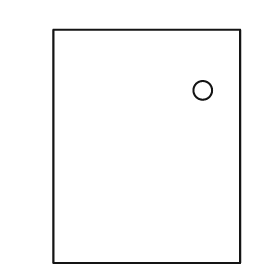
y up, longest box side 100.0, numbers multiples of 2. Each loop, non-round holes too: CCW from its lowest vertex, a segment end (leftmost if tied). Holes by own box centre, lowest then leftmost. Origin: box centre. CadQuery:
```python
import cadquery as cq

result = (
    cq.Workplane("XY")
    .moveTo(-40.0, -50.0)
    .lineTo(40.0, -50.0)
    .lineTo(40.0, 50.0)
    .lineTo(-40.0, 50.0)
    .close()
    .moveTo(24.0, 24.0)
    .circle(4.0)
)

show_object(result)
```